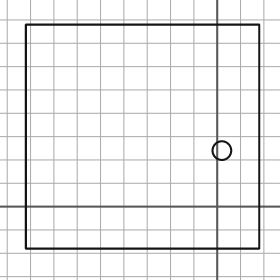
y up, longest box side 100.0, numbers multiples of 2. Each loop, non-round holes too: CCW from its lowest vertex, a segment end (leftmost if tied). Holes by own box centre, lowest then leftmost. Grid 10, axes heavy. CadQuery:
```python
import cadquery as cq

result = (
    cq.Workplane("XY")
    .moveTo(-82.0, -18.0)
    .lineTo(18.0, -18.0)
    .lineTo(18.0, 78.0)
    .lineTo(-82.0, 78.0)
    .close()
    .moveTo(2.0, 24.0)
    .circle(4.0)
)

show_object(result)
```